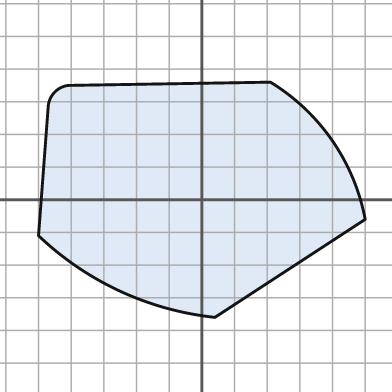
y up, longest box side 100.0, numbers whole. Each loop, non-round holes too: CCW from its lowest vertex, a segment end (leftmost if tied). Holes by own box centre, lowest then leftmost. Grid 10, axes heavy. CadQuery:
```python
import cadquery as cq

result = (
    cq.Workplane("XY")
    .moveTo(4.0, -36.0)
    .lineTo(50.0, -6.0)
    .threePointArc((40.0, 18.0), (21.0, 36.0))
    .lineTo(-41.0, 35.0)
    .threePointArc((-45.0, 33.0), (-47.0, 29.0))
    .lineTo(-50.0, -11.0)
    .threePointArc((-25.0, -28.0), (4.0, -36.0))
    .close()
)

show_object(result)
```